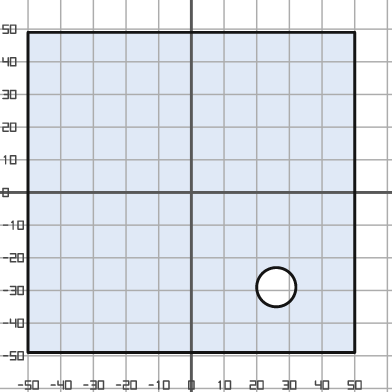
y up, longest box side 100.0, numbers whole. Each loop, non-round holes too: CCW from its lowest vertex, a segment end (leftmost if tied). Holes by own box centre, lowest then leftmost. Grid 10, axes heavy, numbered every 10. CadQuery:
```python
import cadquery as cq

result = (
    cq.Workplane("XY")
    .moveTo(-50.0, -49.0)
    .lineTo(50.0, -49.0)
    .lineTo(50.0, 49.0)
    .lineTo(-50.0, 49.0)
    .close()
    .moveTo(26.0, -29.0)
    .circle(6.0)
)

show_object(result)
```